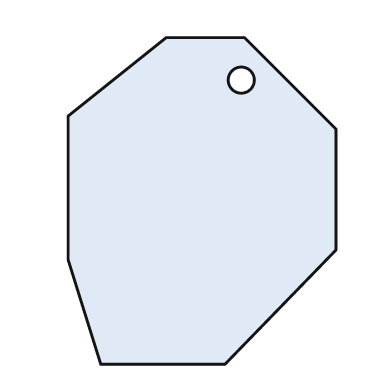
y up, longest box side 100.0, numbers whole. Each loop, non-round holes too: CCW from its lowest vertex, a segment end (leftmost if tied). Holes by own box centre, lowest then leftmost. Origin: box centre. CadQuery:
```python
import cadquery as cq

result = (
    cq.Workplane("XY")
    .moveTo(-31.0, -50.0)
    .lineTo(7.0, -50.0)
    .lineTo(41.0, -15.0)
    .lineTo(41.0, 22.0)
    .lineTo(13.0, 50.0)
    .lineTo(-11.0, 50.0)
    .lineTo(-41.0, 26.0)
    .lineTo(-41.0, -18.0)
    .close()
    .moveTo(12.0, 37.0)
    .circle(4.0)
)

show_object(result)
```